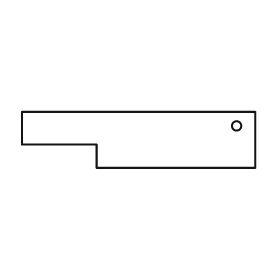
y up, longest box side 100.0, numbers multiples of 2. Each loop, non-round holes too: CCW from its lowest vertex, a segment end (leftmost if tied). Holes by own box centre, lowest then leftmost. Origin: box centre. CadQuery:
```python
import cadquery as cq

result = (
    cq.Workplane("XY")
    .moveTo(-18.0, -12.0)
    .lineTo(50.0, -12.0)
    .lineTo(50.0, 12.0)
    .lineTo(-50.0, 12.0)
    .lineTo(-50.0, -2.0)
    .lineTo(-18.0, -2.0)
    .close()
    .moveTo(42.0, 6.0)
    .circle(2.0)
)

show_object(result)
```